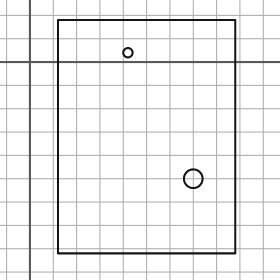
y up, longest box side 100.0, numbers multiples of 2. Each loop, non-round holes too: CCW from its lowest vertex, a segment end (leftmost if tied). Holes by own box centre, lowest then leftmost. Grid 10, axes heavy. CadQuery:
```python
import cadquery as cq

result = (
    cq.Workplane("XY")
    .moveTo(12.0, -82.0)
    .lineTo(88.0, -82.0)
    .lineTo(88.0, 18.0)
    .lineTo(12.0, 18.0)
    .close()
    .moveTo(70.0, -50.0)
    .circle(4.0)
    .moveTo(42.0, 4.0)
    .circle(2.0)
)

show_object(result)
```